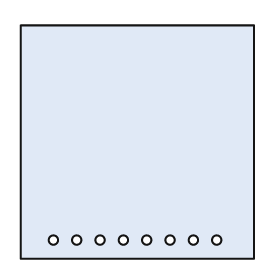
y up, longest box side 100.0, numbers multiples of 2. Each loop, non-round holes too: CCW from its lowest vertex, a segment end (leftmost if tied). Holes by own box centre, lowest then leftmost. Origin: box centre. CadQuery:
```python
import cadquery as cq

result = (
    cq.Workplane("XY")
    .moveTo(-50.0, -50.0)
    .lineTo(50.0, -50.0)
    .lineTo(50.0, 50.0)
    .lineTo(-50.0, 50.0)
    .close()
    .moveTo(-36.0, -42.0)
    .circle(2.0)
    .moveTo(-26.0, -42.0)
    .circle(2.0)
    .moveTo(-16.0, -42.0)
    .circle(2.0)
    .moveTo(-6.0, -42.0)
    .circle(2.0)
    .moveTo(4.0, -42.0)
    .circle(2.0)
    .moveTo(14.0, -42.0)
    .circle(2.0)
    .moveTo(24.0, -42.0)
    .circle(2.0)
    .moveTo(34.0, -42.0)
    .circle(2.0)
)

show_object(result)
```